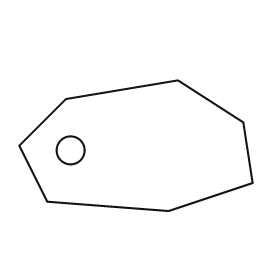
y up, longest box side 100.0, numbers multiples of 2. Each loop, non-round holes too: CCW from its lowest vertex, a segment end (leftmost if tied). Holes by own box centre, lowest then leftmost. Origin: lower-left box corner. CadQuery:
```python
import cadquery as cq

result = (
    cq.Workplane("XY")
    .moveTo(64.0, 0.0)
    .lineTo(100.0, 12.0)
    .lineTo(96.0, 38.0)
    .lineTo(68.0, 56.0)
    .lineTo(20.0, 48.0)
    .lineTo(0.0, 28.0)
    .lineTo(12.0, 4.0)
    .close()
    .moveTo(22.0, 26.0)
    .circle(6.0)
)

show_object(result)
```